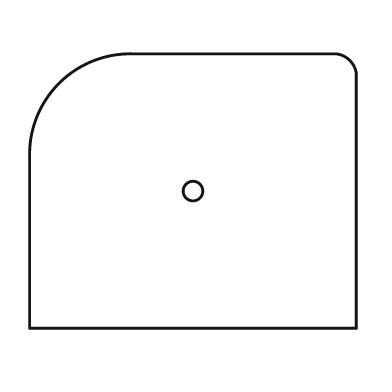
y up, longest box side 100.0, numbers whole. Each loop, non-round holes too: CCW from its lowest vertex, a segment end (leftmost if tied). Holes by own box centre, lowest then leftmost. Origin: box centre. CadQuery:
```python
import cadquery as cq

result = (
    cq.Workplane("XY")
    .moveTo(-50.0, -42.0)
    .lineTo(50.0, -42.0)
    .lineTo(50.0, 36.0)
    .threePointArc((48.0, 40.0), (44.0, 42.0))
    .lineTo(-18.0, 42.0)
    .threePointArc((-41.0, 33.0), (-50.0, 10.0))
    .close()
    .moveTo(0.0, 0.0)
    .circle(3.0)
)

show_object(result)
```